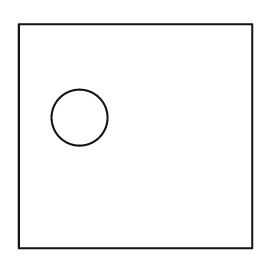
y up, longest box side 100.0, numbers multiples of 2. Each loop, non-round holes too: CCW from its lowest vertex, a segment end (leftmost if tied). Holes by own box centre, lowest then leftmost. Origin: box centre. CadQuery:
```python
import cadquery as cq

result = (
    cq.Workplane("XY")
    .moveTo(-50.0, -48.0)
    .lineTo(50.0, -48.0)
    .lineTo(50.0, 48.0)
    .lineTo(-50.0, 48.0)
    .close()
    .moveTo(-24.0, 8.0)
    .circle(12.0)
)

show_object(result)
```